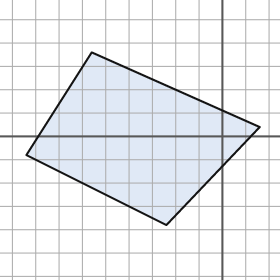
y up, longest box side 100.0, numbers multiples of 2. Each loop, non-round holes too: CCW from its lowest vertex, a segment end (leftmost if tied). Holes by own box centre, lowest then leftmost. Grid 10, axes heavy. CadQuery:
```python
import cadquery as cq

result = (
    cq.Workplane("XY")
    .moveTo(-24.0, -38.0)
    .lineTo(16.0, 4.0)
    .lineTo(-56.0, 36.0)
    .lineTo(-84.0, -8.0)
    .close()
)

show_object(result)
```